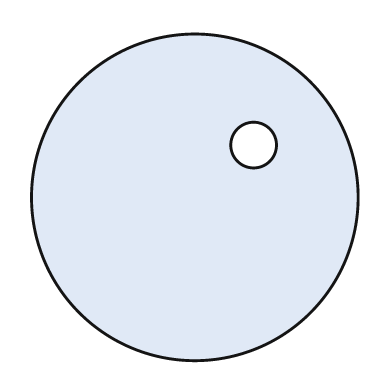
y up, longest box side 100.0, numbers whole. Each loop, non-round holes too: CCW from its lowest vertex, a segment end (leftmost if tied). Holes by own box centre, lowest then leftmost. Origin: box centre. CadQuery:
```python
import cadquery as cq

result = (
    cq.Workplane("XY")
    .moveTo(0.0, 0.0)
    .circle(50.0)
    .moveTo(18.0, 16.0)
    .circle(7.0)
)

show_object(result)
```